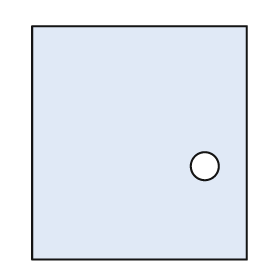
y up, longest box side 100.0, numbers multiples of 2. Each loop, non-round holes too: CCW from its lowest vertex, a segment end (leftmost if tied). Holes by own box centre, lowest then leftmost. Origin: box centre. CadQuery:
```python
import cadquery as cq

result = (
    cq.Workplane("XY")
    .moveTo(-46.0, -50.0)
    .lineTo(46.0, -50.0)
    .lineTo(46.0, 50.0)
    .lineTo(-46.0, 50.0)
    .close()
    .moveTo(28.0, -10.0)
    .circle(6.0)
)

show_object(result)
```